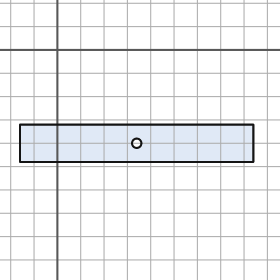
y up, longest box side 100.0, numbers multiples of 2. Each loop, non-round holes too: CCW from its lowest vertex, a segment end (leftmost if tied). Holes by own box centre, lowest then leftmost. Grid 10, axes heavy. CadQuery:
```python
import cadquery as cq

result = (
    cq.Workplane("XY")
    .moveTo(-16.0, -48.0)
    .lineTo(84.0, -48.0)
    .lineTo(84.0, -32.0)
    .lineTo(-16.0, -32.0)
    .close()
    .moveTo(34.0, -40.0)
    .circle(2.0)
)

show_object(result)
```